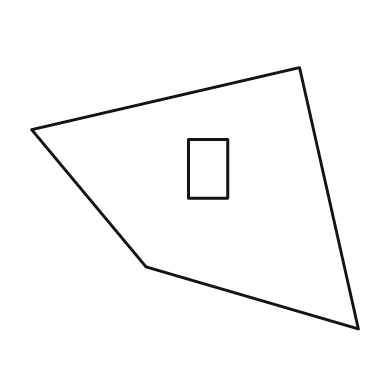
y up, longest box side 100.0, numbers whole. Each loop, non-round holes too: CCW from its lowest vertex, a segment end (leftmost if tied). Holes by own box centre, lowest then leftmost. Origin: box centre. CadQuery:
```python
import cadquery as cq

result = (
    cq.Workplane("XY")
    .moveTo(50.0, -40.0)
    .lineTo(32.0, 40.0)
    .lineTo(-50.0, 21.0)
    .lineTo(-15.0, -21.0)
    .close()
    .moveTo(-2.0, 0.0)
    .lineTo(10.0, 0.0)
    .lineTo(10.0, 18.0)
    .lineTo(-2.0, 18.0)
    .close()
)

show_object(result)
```